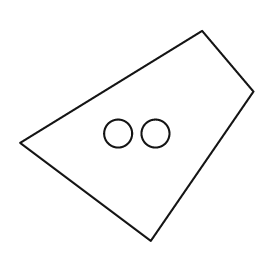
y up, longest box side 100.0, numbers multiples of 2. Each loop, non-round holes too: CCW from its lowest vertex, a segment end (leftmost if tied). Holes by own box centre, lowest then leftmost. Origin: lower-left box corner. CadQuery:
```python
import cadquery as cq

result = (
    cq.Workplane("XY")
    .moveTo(56.0, 0.0)
    .lineTo(100.0, 64.0)
    .lineTo(78.0, 90.0)
    .lineTo(0.0, 42.0)
    .close()
    .moveTo(42.0, 46.0)
    .circle(6.0)
    .moveTo(58.0, 46.0)
    .circle(6.0)
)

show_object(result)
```